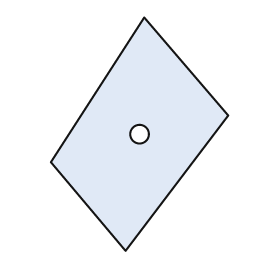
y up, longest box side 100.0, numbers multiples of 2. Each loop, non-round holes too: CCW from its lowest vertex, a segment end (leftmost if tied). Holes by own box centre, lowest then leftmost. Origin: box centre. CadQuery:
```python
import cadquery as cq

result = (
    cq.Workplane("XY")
    .moveTo(-6.0, -50.0)
    .lineTo(38.0, 8.0)
    .lineTo(2.0, 50.0)
    .lineTo(-38.0, -12.0)
    .close()
    .moveTo(0.0, 0.0)
    .circle(4.0)
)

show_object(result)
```